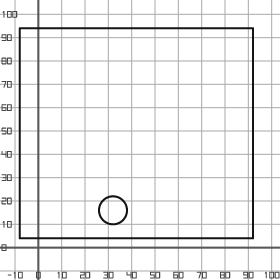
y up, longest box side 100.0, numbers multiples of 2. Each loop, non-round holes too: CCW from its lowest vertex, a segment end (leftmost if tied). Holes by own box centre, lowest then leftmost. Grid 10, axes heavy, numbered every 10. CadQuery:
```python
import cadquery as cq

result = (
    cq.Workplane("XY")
    .moveTo(-8.0, 4.0)
    .lineTo(92.0, 4.0)
    .lineTo(92.0, 94.0)
    .lineTo(-8.0, 94.0)
    .close()
    .moveTo(32.0, 16.0)
    .circle(6.0)
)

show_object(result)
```